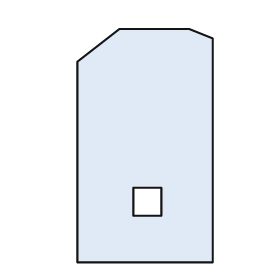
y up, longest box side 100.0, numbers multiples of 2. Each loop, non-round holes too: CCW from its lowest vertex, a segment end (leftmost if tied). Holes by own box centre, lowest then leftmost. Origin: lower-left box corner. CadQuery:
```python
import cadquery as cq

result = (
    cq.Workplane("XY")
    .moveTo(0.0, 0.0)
    .lineTo(58.0, 0.0)
    .lineTo(58.0, 96.0)
    .lineTo(48.0, 100.0)
    .lineTo(18.0, 100.0)
    .lineTo(0.0, 86.0)
    .close()
    .moveTo(24.0, 20.0)
    .lineTo(36.0, 20.0)
    .lineTo(36.0, 32.0)
    .lineTo(24.0, 32.0)
    .close()
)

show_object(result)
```